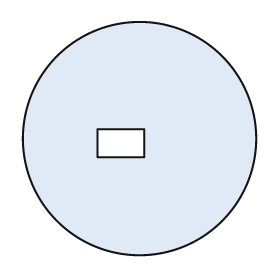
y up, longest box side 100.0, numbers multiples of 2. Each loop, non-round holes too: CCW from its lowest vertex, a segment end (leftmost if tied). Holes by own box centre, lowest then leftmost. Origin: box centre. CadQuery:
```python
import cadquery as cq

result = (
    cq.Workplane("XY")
    .moveTo(0.0, 0.0)
    .circle(50.0)
    .moveTo(-18.0, -8.0)
    .lineTo(2.0, -8.0)
    .lineTo(2.0, 4.0)
    .lineTo(-18.0, 4.0)
    .close()
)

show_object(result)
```